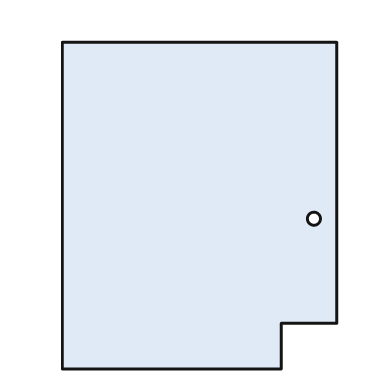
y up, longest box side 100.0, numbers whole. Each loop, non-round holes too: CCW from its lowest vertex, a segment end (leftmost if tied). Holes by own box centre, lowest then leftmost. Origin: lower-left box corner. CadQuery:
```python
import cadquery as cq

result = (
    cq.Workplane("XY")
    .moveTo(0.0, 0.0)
    .lineTo(67.0, 0.0)
    .lineTo(67.0, 14.0)
    .lineTo(84.0, 14.0)
    .lineTo(84.0, 100.0)
    .lineTo(0.0, 100.0)
    .close()
    .moveTo(77.0, 46.0)
    .circle(2.0)
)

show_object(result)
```